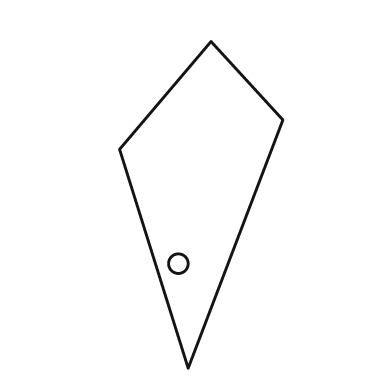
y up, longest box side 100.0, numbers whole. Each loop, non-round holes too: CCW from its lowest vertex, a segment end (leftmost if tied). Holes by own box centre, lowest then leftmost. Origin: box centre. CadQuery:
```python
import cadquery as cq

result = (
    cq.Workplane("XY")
    .moveTo(-4.0, -50.0)
    .lineTo(25.0, 26.0)
    .lineTo(3.0, 50.0)
    .lineTo(-25.0, 17.0)
    .close()
    .moveTo(-7.0, -18.0)
    .circle(3.0)
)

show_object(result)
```